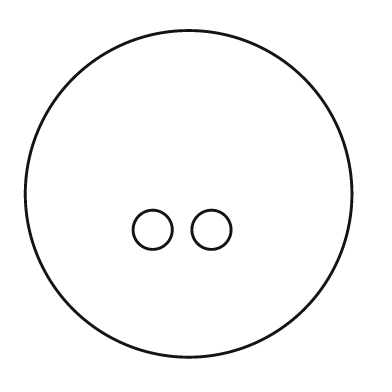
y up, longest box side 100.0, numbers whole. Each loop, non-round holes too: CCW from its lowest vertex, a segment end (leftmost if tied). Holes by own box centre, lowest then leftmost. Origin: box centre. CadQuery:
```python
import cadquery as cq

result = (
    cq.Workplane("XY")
    .moveTo(0.0, 0.0)
    .circle(50.0)
    .moveTo(-11.0, -11.0)
    .circle(6.0)
    .moveTo(7.0, -11.0)
    .circle(6.0)
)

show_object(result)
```